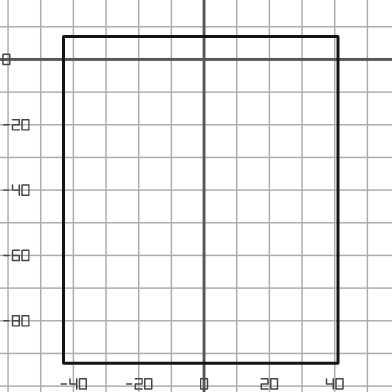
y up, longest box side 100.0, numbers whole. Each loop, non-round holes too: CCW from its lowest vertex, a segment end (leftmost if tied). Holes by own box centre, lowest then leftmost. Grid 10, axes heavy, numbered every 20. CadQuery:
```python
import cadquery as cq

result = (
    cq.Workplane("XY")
    .moveTo(-43.0, -93.0)
    .lineTo(41.0, -93.0)
    .lineTo(41.0, 7.0)
    .lineTo(-43.0, 7.0)
    .close()
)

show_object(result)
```